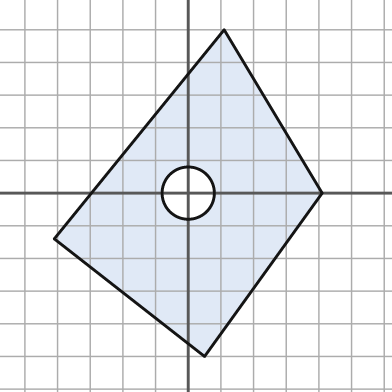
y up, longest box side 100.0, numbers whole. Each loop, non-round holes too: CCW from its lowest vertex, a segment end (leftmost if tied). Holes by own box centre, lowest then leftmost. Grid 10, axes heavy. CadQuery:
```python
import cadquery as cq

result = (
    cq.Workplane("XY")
    .moveTo(5.0, -50.0)
    .lineTo(41.0, 0.0)
    .lineTo(11.0, 50.0)
    .lineTo(-41.0, -14.0)
    .close()
    .moveTo(0.0, 0.0)
    .circle(8.0)
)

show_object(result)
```